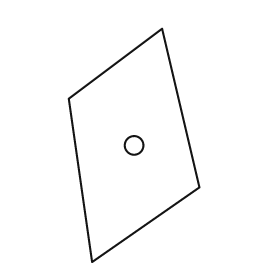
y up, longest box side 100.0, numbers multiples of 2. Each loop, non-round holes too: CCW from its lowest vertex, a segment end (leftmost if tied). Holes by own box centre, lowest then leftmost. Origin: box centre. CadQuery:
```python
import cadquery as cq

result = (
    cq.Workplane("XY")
    .moveTo(-18.0, -50.0)
    .lineTo(28.0, -18.0)
    .lineTo(12.0, 50.0)
    .lineTo(-28.0, 20.0)
    .close()
    .moveTo(0.0, 0.0)
    .circle(4.0)
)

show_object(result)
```